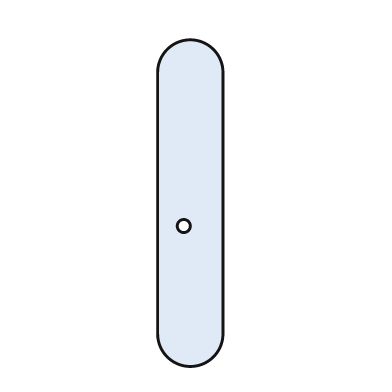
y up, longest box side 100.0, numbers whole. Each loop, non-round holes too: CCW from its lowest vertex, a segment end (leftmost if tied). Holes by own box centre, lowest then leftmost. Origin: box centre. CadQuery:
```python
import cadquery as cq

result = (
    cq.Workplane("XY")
    .moveTo(-10.0, -40.0)
    .threePointArc((0.0, -50.0), (10.0, -40.0))
    .lineTo(10.0, 40.0)
    .threePointArc((0.0, 50.0), (-10.0, 40.0))
    .close()
    .moveTo(-2.0, -7.0)
    .circle(2.0)
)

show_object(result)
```